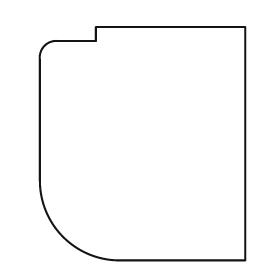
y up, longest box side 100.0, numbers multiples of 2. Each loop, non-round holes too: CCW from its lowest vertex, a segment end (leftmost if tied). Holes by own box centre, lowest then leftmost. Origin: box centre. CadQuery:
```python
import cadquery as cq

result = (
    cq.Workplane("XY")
    .moveTo(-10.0, -50.0)
    .lineTo(44.0, -50.0)
    .lineTo(44.0, 50.0)
    .lineTo(-20.0, 50.0)
    .lineTo(-20.0, 44.0)
    .lineTo(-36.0, 44.0)
    .threePointArc((-42.0, 42.0), (-44.0, 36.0))
    .lineTo(-44.0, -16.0)
    .threePointArc((-34.0, -40.0), (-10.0, -50.0))
    .close()
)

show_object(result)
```